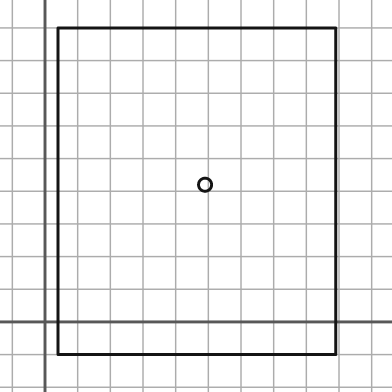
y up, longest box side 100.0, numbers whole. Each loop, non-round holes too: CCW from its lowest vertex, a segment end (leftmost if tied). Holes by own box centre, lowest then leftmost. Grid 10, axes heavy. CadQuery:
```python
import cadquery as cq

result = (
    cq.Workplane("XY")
    .moveTo(4.0, -10.0)
    .lineTo(89.0, -10.0)
    .lineTo(89.0, 90.0)
    .lineTo(4.0, 90.0)
    .close()
    .moveTo(49.0, 42.0)
    .circle(2.0)
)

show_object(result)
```